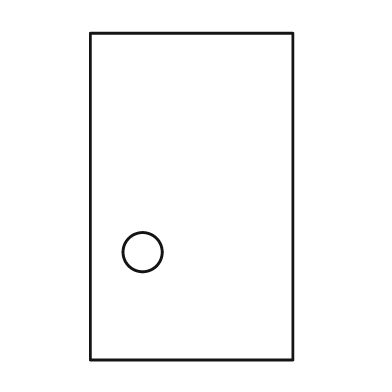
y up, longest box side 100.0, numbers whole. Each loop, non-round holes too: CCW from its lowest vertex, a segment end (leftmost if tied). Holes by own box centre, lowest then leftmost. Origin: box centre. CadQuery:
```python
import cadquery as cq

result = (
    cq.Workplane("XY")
    .moveTo(-31.0, -50.0)
    .lineTo(31.0, -50.0)
    .lineTo(31.0, 50.0)
    .lineTo(-31.0, 50.0)
    .close()
    .moveTo(-15.0, -17.0)
    .circle(6.0)
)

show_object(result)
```